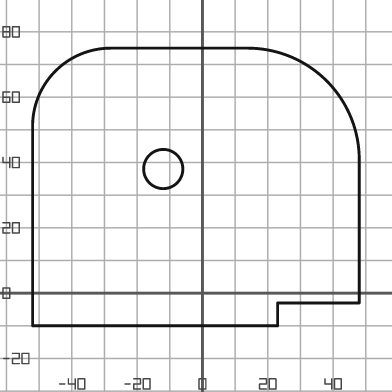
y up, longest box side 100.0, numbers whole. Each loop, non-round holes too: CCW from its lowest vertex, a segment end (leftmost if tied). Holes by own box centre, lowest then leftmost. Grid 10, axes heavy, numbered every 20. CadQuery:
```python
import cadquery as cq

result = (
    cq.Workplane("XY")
    .moveTo(-52.0, -10.0)
    .lineTo(23.0, -10.0)
    .lineTo(23.0, -3.0)
    .lineTo(48.0, -3.0)
    .lineTo(48.0, 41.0)
    .threePointArc((38.0, 65.0), (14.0, 75.0))
    .lineTo(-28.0, 75.0)
    .threePointArc((-45.0, 68.0), (-52.0, 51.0))
    .close()
    .moveTo(-12.0, 38.0)
    .circle(6.0)
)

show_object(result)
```